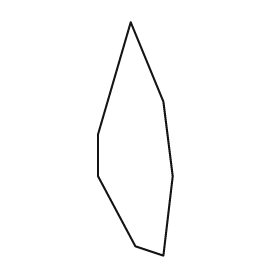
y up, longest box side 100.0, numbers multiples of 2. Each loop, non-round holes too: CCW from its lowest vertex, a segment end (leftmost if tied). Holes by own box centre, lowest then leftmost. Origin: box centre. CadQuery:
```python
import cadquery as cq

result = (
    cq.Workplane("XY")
    .moveTo(12.0, -50.0)
    .lineTo(16.0, -16.0)
    .lineTo(12.0, 16.0)
    .lineTo(-2.0, 50.0)
    .lineTo(-16.0, 2.0)
    .lineTo(-16.0, -16.0)
    .lineTo(0.0, -46.0)
    .close()
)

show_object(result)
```